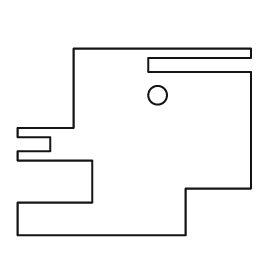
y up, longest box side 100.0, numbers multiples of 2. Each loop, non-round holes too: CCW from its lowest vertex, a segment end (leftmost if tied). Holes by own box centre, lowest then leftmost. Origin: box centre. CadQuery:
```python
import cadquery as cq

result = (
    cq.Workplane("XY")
    .moveTo(-50.0, -40.0)
    .lineTo(22.0, -40.0)
    .lineTo(22.0, -20.0)
    .lineTo(50.0, -20.0)
    .lineTo(50.0, 30.0)
    .lineTo(6.0, 30.0)
    .lineTo(6.0, 36.0)
    .lineTo(50.0, 36.0)
    .lineTo(50.0, 40.0)
    .lineTo(-26.0, 40.0)
    .lineTo(-26.0, 6.0)
    .lineTo(-50.0, 6.0)
    .lineTo(-50.0, 2.0)
    .lineTo(-36.0, 2.0)
    .lineTo(-36.0, -4.0)
    .lineTo(-50.0, -4.0)
    .lineTo(-50.0, -8.0)
    .lineTo(-18.0, -8.0)
    .lineTo(-18.0, -26.0)
    .lineTo(-50.0, -26.0)
    .close()
    .moveTo(10.0, 20.0)
    .circle(4.0)
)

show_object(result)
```